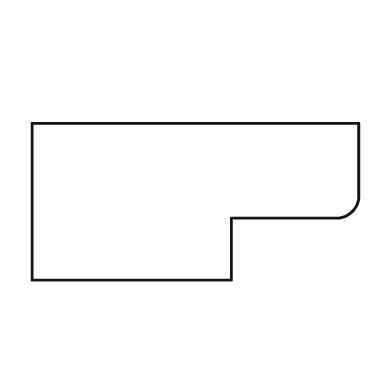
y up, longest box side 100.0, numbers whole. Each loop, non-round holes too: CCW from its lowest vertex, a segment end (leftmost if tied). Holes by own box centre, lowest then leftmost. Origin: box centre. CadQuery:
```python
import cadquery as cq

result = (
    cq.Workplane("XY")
    .moveTo(-50.0, -24.0)
    .lineTo(11.0, -24.0)
    .lineTo(11.0, -5.0)
    .lineTo(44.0, -5.0)
    .threePointArc((48.0, -3.0), (50.0, 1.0))
    .lineTo(50.0, 24.0)
    .lineTo(-50.0, 24.0)
    .close()
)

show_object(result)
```